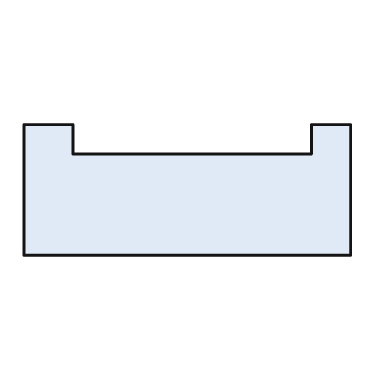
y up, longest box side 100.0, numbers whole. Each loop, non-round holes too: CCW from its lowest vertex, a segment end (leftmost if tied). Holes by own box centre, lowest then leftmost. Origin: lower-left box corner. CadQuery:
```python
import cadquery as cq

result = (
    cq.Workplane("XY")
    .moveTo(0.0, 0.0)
    .lineTo(100.0, 0.0)
    .lineTo(100.0, 40.0)
    .lineTo(88.0, 40.0)
    .lineTo(88.0, 31.0)
    .lineTo(15.0, 31.0)
    .lineTo(15.0, 40.0)
    .lineTo(0.0, 40.0)
    .close()
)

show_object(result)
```